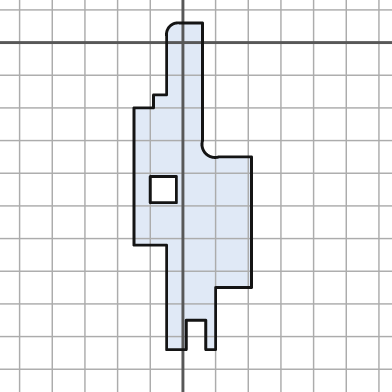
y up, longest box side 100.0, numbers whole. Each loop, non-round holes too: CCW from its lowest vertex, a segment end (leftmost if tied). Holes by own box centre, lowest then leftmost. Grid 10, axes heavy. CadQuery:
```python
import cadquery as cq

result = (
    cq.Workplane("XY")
    .moveTo(-5.0, -94.0)
    .lineTo(1.0, -94.0)
    .lineTo(1.0, -85.0)
    .lineTo(7.0, -85.0)
    .lineTo(7.0, -94.0)
    .lineTo(10.0, -94.0)
    .lineTo(10.0, -75.0)
    .lineTo(21.0, -75.0)
    .lineTo(21.0, -35.0)
    .lineTo(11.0, -35.0)
    .threePointArc((7.0, -34.0), (6.0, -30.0))
    .lineTo(6.0, 6.0)
    .lineTo(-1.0, 6.0)
    .threePointArc((-4.0, 5.0), (-5.0, 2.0))
    .lineTo(-5.0, -16.0)
    .lineTo(-9.0, -16.0)
    .lineTo(-9.0, -20.0)
    .lineTo(-15.0, -20.0)
    .lineTo(-15.0, -62.0)
    .lineTo(-5.0, -62.0)
    .close()
    .moveTo(-10.0, -49.0)
    .lineTo(-2.0, -49.0)
    .lineTo(-2.0, -41.0)
    .lineTo(-10.0, -41.0)
    .close()
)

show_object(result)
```